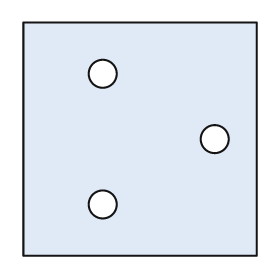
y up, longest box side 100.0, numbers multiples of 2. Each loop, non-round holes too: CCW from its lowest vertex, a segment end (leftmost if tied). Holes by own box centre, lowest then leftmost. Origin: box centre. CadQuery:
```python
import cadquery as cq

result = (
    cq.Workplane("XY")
    .moveTo(-50.0, -50.0)
    .lineTo(50.0, -50.0)
    .lineTo(50.0, 50.0)
    .lineTo(-50.0, 50.0)
    .close()
    .moveTo(-16.0, -28.0)
    .circle(6.0)
    .moveTo(32.0, 0.0)
    .circle(6.0)
    .moveTo(-16.0, 28.0)
    .circle(6.0)
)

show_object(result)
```